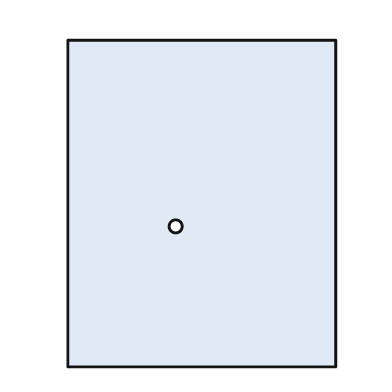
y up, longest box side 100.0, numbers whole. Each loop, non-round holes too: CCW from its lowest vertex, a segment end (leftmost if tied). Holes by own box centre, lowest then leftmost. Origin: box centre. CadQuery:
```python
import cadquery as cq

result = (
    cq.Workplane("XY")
    .moveTo(-41.0, -50.0)
    .lineTo(41.0, -50.0)
    .lineTo(41.0, 50.0)
    .lineTo(-41.0, 50.0)
    .close()
    .moveTo(-8.0, -7.0)
    .circle(2.0)
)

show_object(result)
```